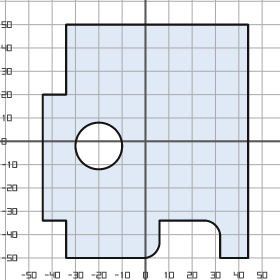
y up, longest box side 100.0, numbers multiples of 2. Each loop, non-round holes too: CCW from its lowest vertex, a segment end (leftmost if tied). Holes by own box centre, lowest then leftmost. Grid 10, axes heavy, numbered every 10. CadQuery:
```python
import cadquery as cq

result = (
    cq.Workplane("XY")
    .moveTo(-34.0, -50.0)
    .lineTo(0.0, -50.0)
    .threePointArc((4.0, -48.0), (6.0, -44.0))
    .lineTo(6.0, -34.0)
    .lineTo(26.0, -34.0)
    .threePointArc((30.0, -36.0), (32.0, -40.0))
    .lineTo(32.0, -50.0)
    .lineTo(44.0, -50.0)
    .lineTo(44.0, 50.0)
    .lineTo(-34.0, 50.0)
    .lineTo(-34.0, 20.0)
    .lineTo(-44.0, 20.0)
    .lineTo(-44.0, -34.0)
    .lineTo(-34.0, -34.0)
    .close()
    .moveTo(-20.0, -2.0)
    .circle(10.0)
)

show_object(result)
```